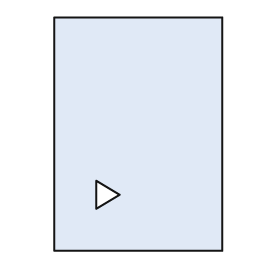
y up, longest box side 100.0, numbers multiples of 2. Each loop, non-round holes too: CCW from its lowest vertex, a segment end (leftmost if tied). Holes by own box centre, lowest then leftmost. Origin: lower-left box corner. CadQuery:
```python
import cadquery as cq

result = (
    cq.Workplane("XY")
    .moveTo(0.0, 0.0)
    .lineTo(72.0, 0.0)
    .lineTo(72.0, 100.0)
    .lineTo(0.0, 100.0)
    .close()
    .moveTo(18.0, 18.0)
    .lineTo(28.0, 24.0)
    .lineTo(18.0, 30.0)
    .close()
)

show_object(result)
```